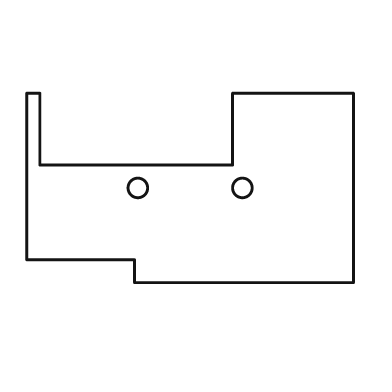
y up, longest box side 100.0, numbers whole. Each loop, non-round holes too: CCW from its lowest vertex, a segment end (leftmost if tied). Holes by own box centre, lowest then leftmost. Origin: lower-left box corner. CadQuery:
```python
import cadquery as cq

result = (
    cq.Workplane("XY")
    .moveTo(33.0, 0.0)
    .lineTo(100.0, 0.0)
    .lineTo(100.0, 58.0)
    .lineTo(63.0, 58.0)
    .lineTo(63.0, 36.0)
    .lineTo(4.0, 36.0)
    .lineTo(4.0, 58.0)
    .lineTo(0.0, 58.0)
    .lineTo(0.0, 7.0)
    .lineTo(33.0, 7.0)
    .close()
    .moveTo(34.0, 29.0)
    .circle(3.0)
    .moveTo(66.0, 29.0)
    .circle(3.0)
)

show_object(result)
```